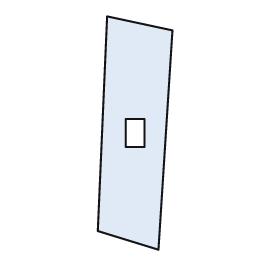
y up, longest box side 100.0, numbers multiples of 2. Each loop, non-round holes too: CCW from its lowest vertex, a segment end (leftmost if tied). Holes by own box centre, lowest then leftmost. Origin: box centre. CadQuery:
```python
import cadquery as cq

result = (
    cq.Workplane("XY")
    .moveTo(10.0, -50.0)
    .lineTo(16.0, 44.0)
    .lineTo(-12.0, 50.0)
    .lineTo(-16.0, -42.0)
    .close()
    .moveTo(-4.0, -6.0)
    .lineTo(4.0, -6.0)
    .lineTo(4.0, 6.0)
    .lineTo(-4.0, 6.0)
    .close()
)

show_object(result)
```